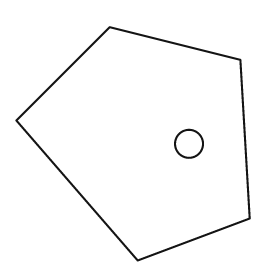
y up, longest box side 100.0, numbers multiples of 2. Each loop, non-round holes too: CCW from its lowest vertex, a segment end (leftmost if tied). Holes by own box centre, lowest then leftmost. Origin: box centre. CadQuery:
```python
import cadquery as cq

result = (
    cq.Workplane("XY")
    .moveTo(2.0, -50.0)
    .lineTo(50.0, -32.0)
    .lineTo(46.0, 36.0)
    .lineTo(-10.0, 50.0)
    .lineTo(-50.0, 10.0)
    .close()
    .moveTo(24.0, 0.0)
    .circle(6.0)
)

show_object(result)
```